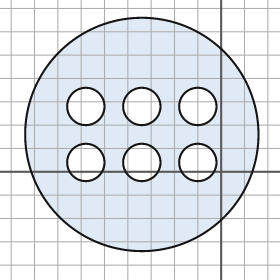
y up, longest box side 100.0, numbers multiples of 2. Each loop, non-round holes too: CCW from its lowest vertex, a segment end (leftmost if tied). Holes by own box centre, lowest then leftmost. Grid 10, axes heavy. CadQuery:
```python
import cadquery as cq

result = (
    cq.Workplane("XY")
    .moveTo(-34.0, 16.0)
    .circle(50.0)
    .moveTo(-58.0, 4.0)
    .circle(8.0)
    .moveTo(-34.0, 4.0)
    .circle(8.0)
    .moveTo(-10.0, 4.0)
    .circle(8.0)
    .moveTo(-58.0, 28.0)
    .circle(8.0)
    .moveTo(-34.0, 28.0)
    .circle(8.0)
    .moveTo(-10.0, 28.0)
    .circle(8.0)
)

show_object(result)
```